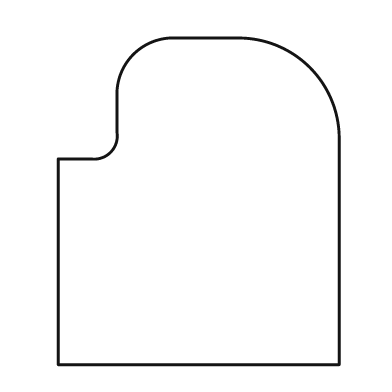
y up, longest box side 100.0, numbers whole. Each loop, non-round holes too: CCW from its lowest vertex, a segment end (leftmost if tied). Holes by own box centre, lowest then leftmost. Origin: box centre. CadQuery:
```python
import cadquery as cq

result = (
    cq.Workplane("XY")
    .moveTo(-43.0, -50.0)
    .lineTo(43.0, -50.0)
    .lineTo(43.0, 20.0)
    .threePointArc((34.0, 41.0), (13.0, 50.0))
    .lineTo(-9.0, 50.0)
    .threePointArc((-20.0, 45.0), (-25.0, 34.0))
    .lineTo(-25.0, 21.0)
    .threePointArc((-27.0, 15.0), (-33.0, 13.0))
    .lineTo(-43.0, 13.0)
    .close()
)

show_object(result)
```